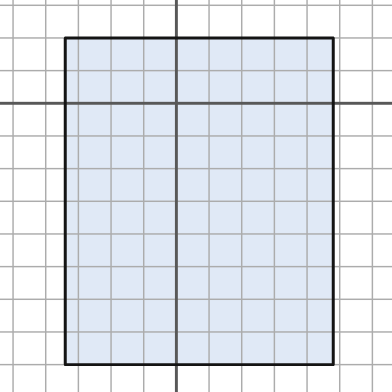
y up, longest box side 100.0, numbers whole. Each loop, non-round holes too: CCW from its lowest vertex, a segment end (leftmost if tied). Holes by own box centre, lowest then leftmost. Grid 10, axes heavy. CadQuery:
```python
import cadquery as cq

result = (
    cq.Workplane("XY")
    .moveTo(-34.0, -80.0)
    .lineTo(48.0, -80.0)
    .lineTo(48.0, 20.0)
    .lineTo(-34.0, 20.0)
    .close()
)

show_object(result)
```